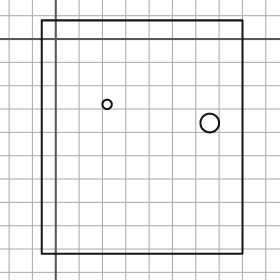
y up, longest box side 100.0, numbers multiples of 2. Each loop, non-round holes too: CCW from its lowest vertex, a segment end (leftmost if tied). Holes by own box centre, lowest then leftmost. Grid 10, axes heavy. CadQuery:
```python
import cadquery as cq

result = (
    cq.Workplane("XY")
    .moveTo(-6.0, -92.0)
    .lineTo(80.0, -92.0)
    .lineTo(80.0, 8.0)
    .lineTo(-6.0, 8.0)
    .close()
    .moveTo(66.0, -36.0)
    .circle(4.0)
    .moveTo(22.0, -28.0)
    .circle(2.0)
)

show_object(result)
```